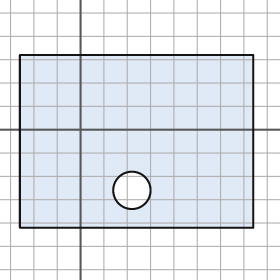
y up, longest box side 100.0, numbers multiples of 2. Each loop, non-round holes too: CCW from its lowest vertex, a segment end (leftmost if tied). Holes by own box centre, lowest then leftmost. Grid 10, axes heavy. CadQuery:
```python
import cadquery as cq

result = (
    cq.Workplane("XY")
    .moveTo(-26.0, -42.0)
    .lineTo(74.0, -42.0)
    .lineTo(74.0, 32.0)
    .lineTo(-26.0, 32.0)
    .close()
    .moveTo(22.0, -26.0)
    .circle(8.0)
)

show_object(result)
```